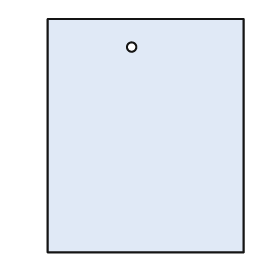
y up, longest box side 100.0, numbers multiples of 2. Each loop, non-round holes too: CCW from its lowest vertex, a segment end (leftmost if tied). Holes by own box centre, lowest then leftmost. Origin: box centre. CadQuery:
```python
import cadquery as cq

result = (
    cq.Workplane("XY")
    .moveTo(-42.0, -50.0)
    .lineTo(42.0, -50.0)
    .lineTo(42.0, 50.0)
    .lineTo(-42.0, 50.0)
    .close()
    .moveTo(-6.0, 38.0)
    .circle(2.0)
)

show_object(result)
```